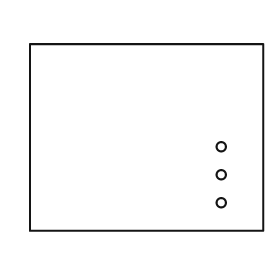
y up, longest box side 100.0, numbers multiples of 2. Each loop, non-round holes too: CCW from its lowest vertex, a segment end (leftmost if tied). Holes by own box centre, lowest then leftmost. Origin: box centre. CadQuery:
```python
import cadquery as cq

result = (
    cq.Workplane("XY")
    .moveTo(-50.0, -40.0)
    .lineTo(50.0, -40.0)
    .lineTo(50.0, 40.0)
    .lineTo(-50.0, 40.0)
    .close()
    .moveTo(32.0, -28.0)
    .circle(2.0)
    .moveTo(32.0, -16.0)
    .circle(2.0)
    .moveTo(32.0, -4.0)
    .circle(2.0)
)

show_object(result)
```